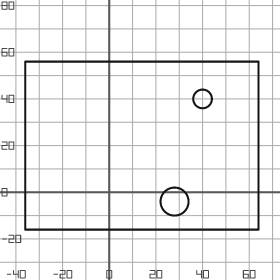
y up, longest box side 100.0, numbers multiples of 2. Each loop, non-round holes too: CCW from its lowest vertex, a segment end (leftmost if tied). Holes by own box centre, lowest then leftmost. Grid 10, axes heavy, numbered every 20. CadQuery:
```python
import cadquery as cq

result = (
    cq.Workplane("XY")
    .moveTo(-36.0, -16.0)
    .lineTo(64.0, -16.0)
    .lineTo(64.0, 56.0)
    .lineTo(-36.0, 56.0)
    .close()
    .moveTo(28.0, -4.0)
    .circle(6.0)
    .moveTo(40.0, 40.0)
    .circle(4.0)
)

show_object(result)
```